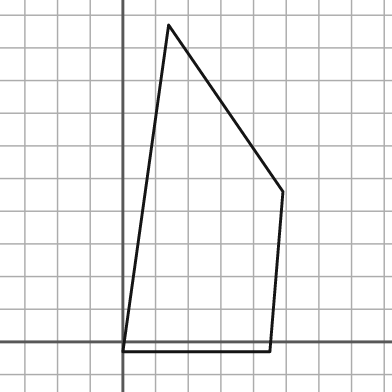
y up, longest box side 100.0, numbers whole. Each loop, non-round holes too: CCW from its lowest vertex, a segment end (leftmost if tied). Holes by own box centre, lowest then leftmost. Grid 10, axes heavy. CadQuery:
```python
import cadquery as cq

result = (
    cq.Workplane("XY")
    .moveTo(0.0, -3.0)
    .lineTo(45.0, -3.0)
    .lineTo(49.0, 46.0)
    .lineTo(14.0, 97.0)
    .close()
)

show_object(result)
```